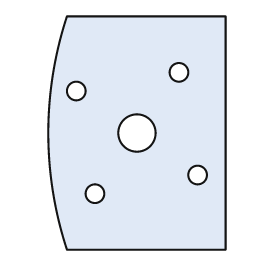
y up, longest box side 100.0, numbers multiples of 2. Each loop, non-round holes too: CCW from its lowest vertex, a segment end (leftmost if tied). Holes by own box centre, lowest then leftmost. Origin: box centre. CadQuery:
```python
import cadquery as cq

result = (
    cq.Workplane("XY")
    .moveTo(-30.0, -50.0)
    .lineTo(38.0, -50.0)
    .lineTo(38.0, 50.0)
    .lineTo(-30.0, 50.0)
    .threePointArc((-38.0, 0.0), (-30.0, -50.0))
    .close()
    .moveTo(-18.0, -26.0)
    .circle(4.0)
    .moveTo(26.0, -18.0)
    .circle(4.0)
    .moveTo(0.0, 0.0)
    .circle(8.0)
    .moveTo(-26.0, 18.0)
    .circle(4.0)
    .moveTo(18.0, 26.0)
    .circle(4.0)
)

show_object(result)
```